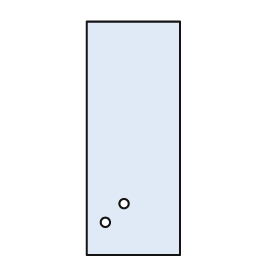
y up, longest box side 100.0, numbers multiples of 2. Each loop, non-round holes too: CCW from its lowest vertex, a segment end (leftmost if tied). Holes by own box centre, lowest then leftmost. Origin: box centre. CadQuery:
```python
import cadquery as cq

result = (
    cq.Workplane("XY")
    .moveTo(-20.0, -50.0)
    .lineTo(20.0, -50.0)
    .lineTo(20.0, 50.0)
    .lineTo(-20.0, 50.0)
    .close()
    .moveTo(-12.0, -36.0)
    .circle(2.0)
    .moveTo(-4.0, -28.0)
    .circle(2.0)
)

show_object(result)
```